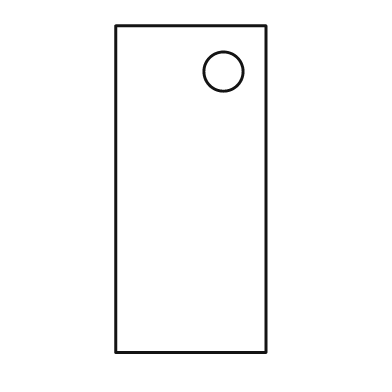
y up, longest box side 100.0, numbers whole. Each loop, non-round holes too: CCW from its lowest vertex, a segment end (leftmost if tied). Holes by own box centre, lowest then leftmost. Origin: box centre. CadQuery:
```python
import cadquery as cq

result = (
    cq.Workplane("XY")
    .moveTo(-23.0, -50.0)
    .lineTo(23.0, -50.0)
    .lineTo(23.0, 50.0)
    .lineTo(-23.0, 50.0)
    .close()
    .moveTo(10.0, 36.0)
    .circle(6.0)
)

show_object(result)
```